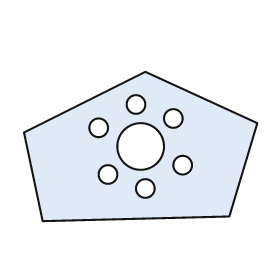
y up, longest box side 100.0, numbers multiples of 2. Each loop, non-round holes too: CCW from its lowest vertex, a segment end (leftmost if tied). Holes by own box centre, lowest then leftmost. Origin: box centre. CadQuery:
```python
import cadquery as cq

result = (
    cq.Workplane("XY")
    .moveTo(-42.0, -32.0)
    .lineTo(38.0, -30.0)
    .lineTo(50.0, 10.0)
    .lineTo(2.0, 32.0)
    .lineTo(-50.0, 6.0)
    .close()
    .moveTo(2.0, -18.0)
    .circle(4.0)
    .moveTo(-14.0, -12.0)
    .circle(4.0)
    .moveTo(18.0, -8.0)
    .circle(4.0)
    .moveTo(0.0, 0.0)
    .circle(10.0)
    .moveTo(-18.0, 8.0)
    .circle(4.0)
    .moveTo(14.0, 12.0)
    .circle(4.0)
    .moveTo(-2.0, 18.0)
    .circle(4.0)
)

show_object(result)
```